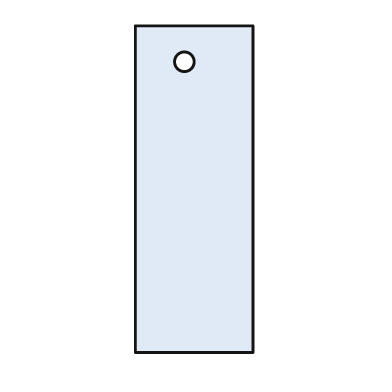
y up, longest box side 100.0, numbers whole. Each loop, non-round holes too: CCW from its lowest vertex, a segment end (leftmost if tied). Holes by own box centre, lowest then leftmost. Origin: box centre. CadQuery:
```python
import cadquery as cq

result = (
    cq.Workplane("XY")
    .moveTo(-18.0, -50.0)
    .lineTo(18.0, -50.0)
    .lineTo(18.0, 50.0)
    .lineTo(-18.0, 50.0)
    .close()
    .moveTo(-3.0, 39.0)
    .circle(3.0)
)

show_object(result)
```